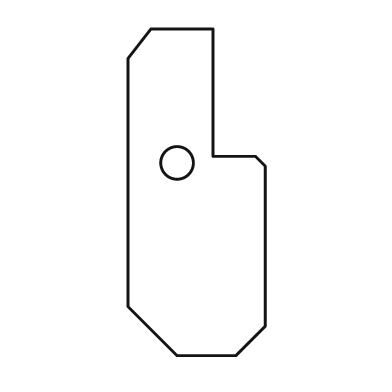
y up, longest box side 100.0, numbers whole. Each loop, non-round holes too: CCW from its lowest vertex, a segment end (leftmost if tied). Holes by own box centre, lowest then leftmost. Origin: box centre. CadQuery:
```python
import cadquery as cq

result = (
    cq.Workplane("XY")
    .moveTo(-6.0, -50.0)
    .lineTo(12.0, -50.0)
    .lineTo(21.0, -41.0)
    .lineTo(21.0, 8.0)
    .lineTo(18.0, 11.0)
    .lineTo(5.0, 11.0)
    .lineTo(5.0, 50.0)
    .lineTo(-14.0, 50.0)
    .lineTo(-21.0, 41.0)
    .lineTo(-21.0, -35.0)
    .close()
    .moveTo(-6.0, 9.0)
    .circle(5.0)
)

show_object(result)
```